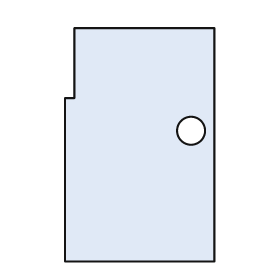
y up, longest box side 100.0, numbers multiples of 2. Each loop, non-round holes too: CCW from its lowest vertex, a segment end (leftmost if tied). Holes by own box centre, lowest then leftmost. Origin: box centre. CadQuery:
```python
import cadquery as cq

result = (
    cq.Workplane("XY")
    .moveTo(-32.0, -50.0)
    .lineTo(32.0, -50.0)
    .lineTo(32.0, 50.0)
    .lineTo(-28.0, 50.0)
    .lineTo(-28.0, 20.0)
    .lineTo(-32.0, 20.0)
    .close()
    .moveTo(22.0, 6.0)
    .circle(6.0)
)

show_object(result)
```